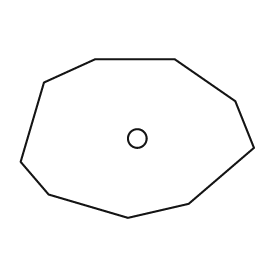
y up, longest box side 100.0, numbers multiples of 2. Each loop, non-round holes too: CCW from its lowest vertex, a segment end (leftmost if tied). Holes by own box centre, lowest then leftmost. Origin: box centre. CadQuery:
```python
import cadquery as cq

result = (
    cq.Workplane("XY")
    .moveTo(-4.0, -34.0)
    .lineTo(22.0, -28.0)
    .lineTo(50.0, -4.0)
    .lineTo(42.0, 16.0)
    .lineTo(16.0, 34.0)
    .lineTo(-18.0, 34.0)
    .lineTo(-40.0, 24.0)
    .lineTo(-50.0, -10.0)
    .lineTo(-38.0, -24.0)
    .close()
    .moveTo(0.0, 0.0)
    .circle(4.0)
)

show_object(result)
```